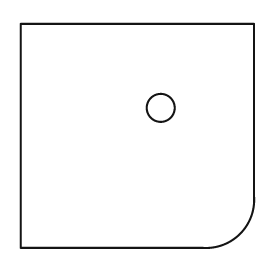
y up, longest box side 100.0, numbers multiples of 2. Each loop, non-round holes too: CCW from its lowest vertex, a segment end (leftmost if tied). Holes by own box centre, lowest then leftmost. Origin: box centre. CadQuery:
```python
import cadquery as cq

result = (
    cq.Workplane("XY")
    .moveTo(-50.0, -48.0)
    .lineTo(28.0, -48.0)
    .threePointArc((44.0, -42.0), (50.0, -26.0))
    .lineTo(50.0, 48.0)
    .lineTo(-50.0, 48.0)
    .close()
    .moveTo(10.0, 12.0)
    .circle(6.0)
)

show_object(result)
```